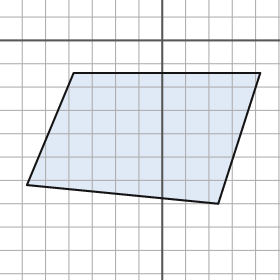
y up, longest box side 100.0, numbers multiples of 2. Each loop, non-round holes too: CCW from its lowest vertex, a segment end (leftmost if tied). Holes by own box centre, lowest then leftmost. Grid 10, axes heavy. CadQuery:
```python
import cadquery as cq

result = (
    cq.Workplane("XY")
    .moveTo(24.0, -70.0)
    .lineTo(42.0, -14.0)
    .lineTo(-38.0, -14.0)
    .lineTo(-58.0, -62.0)
    .close()
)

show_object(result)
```